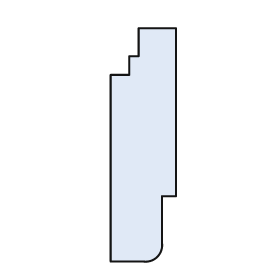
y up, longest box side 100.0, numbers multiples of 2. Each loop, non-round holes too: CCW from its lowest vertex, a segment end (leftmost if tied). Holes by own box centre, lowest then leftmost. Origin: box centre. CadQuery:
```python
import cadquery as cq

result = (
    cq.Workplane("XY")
    .moveTo(-14.0, -50.0)
    .lineTo(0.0, -50.0)
    .threePointArc((6.0, -48.0), (8.0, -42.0))
    .lineTo(8.0, -22.0)
    .lineTo(14.0, -22.0)
    .lineTo(14.0, 50.0)
    .lineTo(-2.0, 50.0)
    .lineTo(-2.0, 38.0)
    .lineTo(-6.0, 38.0)
    .lineTo(-6.0, 30.0)
    .lineTo(-14.0, 30.0)
    .close()
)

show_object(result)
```